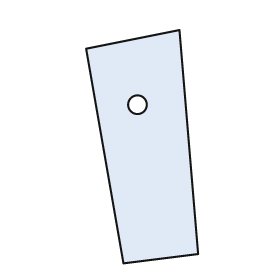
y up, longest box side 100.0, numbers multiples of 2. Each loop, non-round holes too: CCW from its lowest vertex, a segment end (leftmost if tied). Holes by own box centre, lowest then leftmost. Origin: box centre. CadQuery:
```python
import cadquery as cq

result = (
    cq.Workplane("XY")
    .moveTo(-8.0, -50.0)
    .lineTo(24.0, -46.0)
    .lineTo(16.0, 50.0)
    .lineTo(-24.0, 42.0)
    .close()
    .moveTo(-2.0, 18.0)
    .circle(4.0)
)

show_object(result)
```